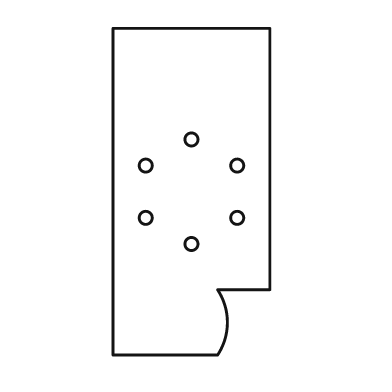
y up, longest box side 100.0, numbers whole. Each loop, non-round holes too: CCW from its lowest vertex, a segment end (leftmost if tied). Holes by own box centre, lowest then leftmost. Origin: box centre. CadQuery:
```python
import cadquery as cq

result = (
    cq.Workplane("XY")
    .moveTo(-24.0, -50.0)
    .lineTo(8.0, -50.0)
    .threePointArc((11.0, -40.0), (8.0, -30.0))
    .lineTo(24.0, -30.0)
    .lineTo(24.0, 50.0)
    .lineTo(-24.0, 50.0)
    .close()
    .moveTo(0.0, -16.0)
    .circle(2.0)
    .moveTo(-14.0, -8.0)
    .circle(2.0)
    .moveTo(14.0, -8.0)
    .circle(2.0)
    .moveTo(-14.0, 8.0)
    .circle(2.0)
    .moveTo(14.0, 8.0)
    .circle(2.0)
    .moveTo(0.0, 16.0)
    .circle(2.0)
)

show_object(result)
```